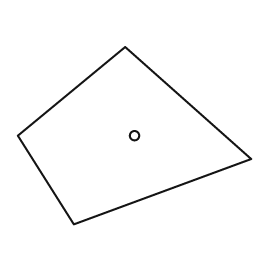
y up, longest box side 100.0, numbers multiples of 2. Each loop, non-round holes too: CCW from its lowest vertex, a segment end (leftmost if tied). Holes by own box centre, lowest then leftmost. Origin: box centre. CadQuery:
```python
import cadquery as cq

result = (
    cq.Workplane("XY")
    .moveTo(-26.0, -38.0)
    .lineTo(50.0, -10.0)
    .lineTo(-4.0, 38.0)
    .lineTo(-50.0, 0.0)
    .close()
    .moveTo(0.0, 0.0)
    .circle(2.0)
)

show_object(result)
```